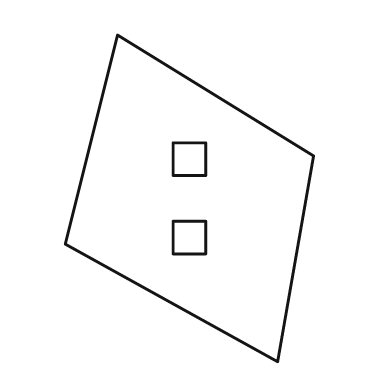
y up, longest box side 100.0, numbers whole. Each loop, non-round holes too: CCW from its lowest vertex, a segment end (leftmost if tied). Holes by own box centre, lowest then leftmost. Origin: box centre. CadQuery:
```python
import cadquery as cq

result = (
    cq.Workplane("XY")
    .moveTo(27.0, -50.0)
    .lineTo(38.0, 13.0)
    .lineTo(-22.0, 50.0)
    .lineTo(-38.0, -14.0)
    .close()
    .moveTo(-5.0, -17.0)
    .lineTo(5.0, -17.0)
    .lineTo(5.0, -7.0)
    .lineTo(-5.0, -7.0)
    .close()
    .moveTo(-5.0, 7.0)
    .lineTo(5.0, 7.0)
    .lineTo(5.0, 17.0)
    .lineTo(-5.0, 17.0)
    .close()
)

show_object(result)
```